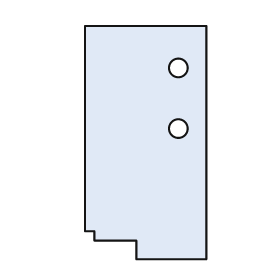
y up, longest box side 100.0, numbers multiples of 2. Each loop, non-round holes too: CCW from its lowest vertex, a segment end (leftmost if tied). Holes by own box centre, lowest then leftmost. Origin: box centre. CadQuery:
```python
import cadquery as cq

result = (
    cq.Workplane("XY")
    .moveTo(-4.0, -50.0)
    .lineTo(26.0, -50.0)
    .lineTo(26.0, 50.0)
    .lineTo(-26.0, 50.0)
    .lineTo(-26.0, -38.0)
    .lineTo(-22.0, -38.0)
    .lineTo(-22.0, -42.0)
    .lineTo(-4.0, -42.0)
    .close()
    .moveTo(14.0, 6.0)
    .circle(4.0)
    .moveTo(14.0, 32.0)
    .circle(4.0)
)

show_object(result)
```